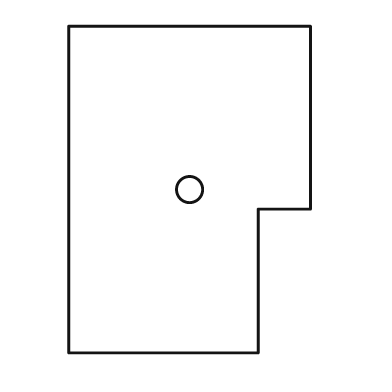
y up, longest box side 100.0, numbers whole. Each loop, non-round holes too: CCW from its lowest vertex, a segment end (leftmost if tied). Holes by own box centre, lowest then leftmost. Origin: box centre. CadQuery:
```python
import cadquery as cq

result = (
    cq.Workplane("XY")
    .moveTo(-37.0, -50.0)
    .lineTo(21.0, -50.0)
    .lineTo(21.0, -6.0)
    .lineTo(37.0, -6.0)
    .lineTo(37.0, 50.0)
    .lineTo(-37.0, 50.0)
    .close()
    .moveTo(0.0, 0.0)
    .circle(4.0)
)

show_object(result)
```